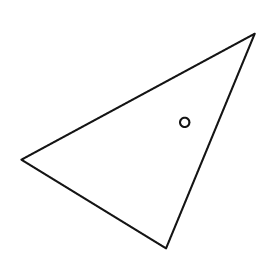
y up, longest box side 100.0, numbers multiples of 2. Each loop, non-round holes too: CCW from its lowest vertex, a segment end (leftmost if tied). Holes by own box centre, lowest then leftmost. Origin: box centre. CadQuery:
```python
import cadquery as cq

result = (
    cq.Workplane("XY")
    .moveTo(12.0, -46.0)
    .lineTo(50.0, 46.0)
    .lineTo(-50.0, -8.0)
    .close()
    .moveTo(20.0, 8.0)
    .circle(2.0)
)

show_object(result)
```